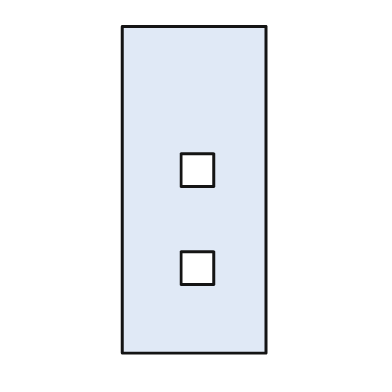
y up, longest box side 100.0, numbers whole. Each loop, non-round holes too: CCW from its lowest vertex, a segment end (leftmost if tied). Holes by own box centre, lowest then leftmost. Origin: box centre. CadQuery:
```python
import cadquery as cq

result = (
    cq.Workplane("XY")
    .moveTo(-22.0, -50.0)
    .lineTo(22.0, -50.0)
    .lineTo(22.0, 50.0)
    .lineTo(-22.0, 50.0)
    .close()
    .moveTo(-4.0, -29.0)
    .lineTo(6.0, -29.0)
    .lineTo(6.0, -19.0)
    .lineTo(-4.0, -19.0)
    .close()
    .moveTo(-4.0, 1.0)
    .lineTo(6.0, 1.0)
    .lineTo(6.0, 11.0)
    .lineTo(-4.0, 11.0)
    .close()
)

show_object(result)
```